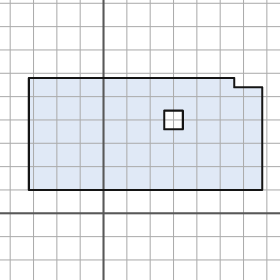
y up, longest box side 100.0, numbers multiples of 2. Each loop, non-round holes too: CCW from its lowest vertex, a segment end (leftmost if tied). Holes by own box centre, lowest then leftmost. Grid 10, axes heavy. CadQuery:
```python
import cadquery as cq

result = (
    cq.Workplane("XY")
    .moveTo(-32.0, 10.0)
    .lineTo(68.0, 10.0)
    .lineTo(68.0, 54.0)
    .lineTo(56.0, 54.0)
    .lineTo(56.0, 58.0)
    .lineTo(-32.0, 58.0)
    .close()
    .moveTo(26.0, 36.0)
    .lineTo(34.0, 36.0)
    .lineTo(34.0, 44.0)
    .lineTo(26.0, 44.0)
    .close()
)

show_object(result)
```